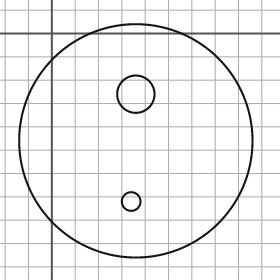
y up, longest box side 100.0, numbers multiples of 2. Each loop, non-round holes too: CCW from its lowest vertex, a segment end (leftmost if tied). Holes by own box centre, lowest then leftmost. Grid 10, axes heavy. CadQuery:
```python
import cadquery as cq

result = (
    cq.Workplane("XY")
    .moveTo(36.0, -46.0)
    .circle(50.0)
    .moveTo(34.0, -72.0)
    .circle(4.0)
    .moveTo(36.0, -26.0)
    .circle(8.0)
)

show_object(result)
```